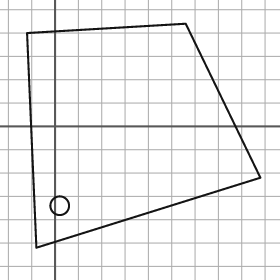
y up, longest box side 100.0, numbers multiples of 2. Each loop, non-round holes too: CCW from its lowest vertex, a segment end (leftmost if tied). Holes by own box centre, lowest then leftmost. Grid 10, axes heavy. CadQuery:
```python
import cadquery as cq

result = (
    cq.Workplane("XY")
    .moveTo(-8.0, -52.0)
    .lineTo(88.0, -22.0)
    .lineTo(56.0, 44.0)
    .lineTo(-12.0, 40.0)
    .close()
    .moveTo(2.0, -34.0)
    .circle(4.0)
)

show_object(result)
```